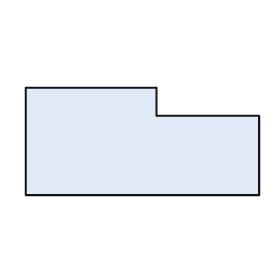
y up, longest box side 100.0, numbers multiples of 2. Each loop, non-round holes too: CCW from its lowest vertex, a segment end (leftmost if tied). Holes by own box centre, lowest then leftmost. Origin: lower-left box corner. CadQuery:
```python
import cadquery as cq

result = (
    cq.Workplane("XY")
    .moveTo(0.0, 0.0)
    .lineTo(100.0, 0.0)
    .lineTo(100.0, 34.0)
    .lineTo(56.0, 34.0)
    .lineTo(56.0, 46.0)
    .lineTo(0.0, 46.0)
    .close()
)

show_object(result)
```